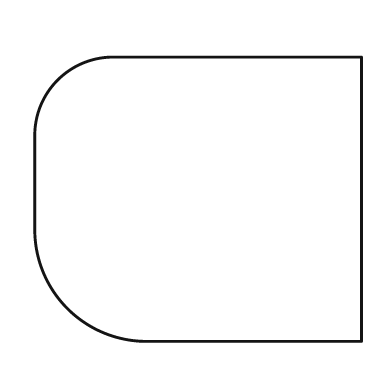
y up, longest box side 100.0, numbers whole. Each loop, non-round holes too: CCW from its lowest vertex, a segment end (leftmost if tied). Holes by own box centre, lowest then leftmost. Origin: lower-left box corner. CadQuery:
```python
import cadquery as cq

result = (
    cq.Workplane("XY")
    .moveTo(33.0, 0.0)
    .lineTo(100.0, 0.0)
    .lineTo(100.0, 87.0)
    .lineTo(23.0, 87.0)
    .threePointArc((7.0, 80.0), (0.0, 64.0))
    .lineTo(0.0, 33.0)
    .threePointArc((10.0, 10.0), (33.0, 0.0))
    .close()
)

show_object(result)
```